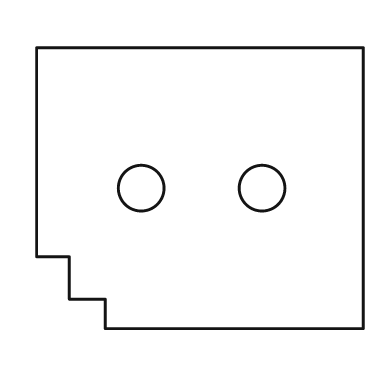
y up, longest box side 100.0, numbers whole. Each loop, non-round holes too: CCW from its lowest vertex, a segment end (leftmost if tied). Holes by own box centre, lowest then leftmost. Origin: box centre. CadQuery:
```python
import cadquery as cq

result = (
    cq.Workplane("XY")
    .moveTo(-29.0, -43.0)
    .lineTo(50.0, -43.0)
    .lineTo(50.0, 43.0)
    .lineTo(-50.0, 43.0)
    .lineTo(-50.0, -21.0)
    .lineTo(-40.0, -21.0)
    .lineTo(-40.0, -34.0)
    .lineTo(-29.0, -34.0)
    .close()
    .moveTo(-18.0, 0.0)
    .circle(7.0)
    .moveTo(19.0, 0.0)
    .circle(7.0)
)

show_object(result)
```